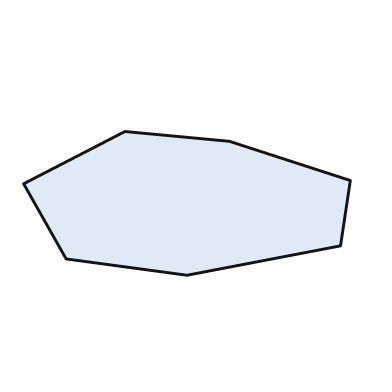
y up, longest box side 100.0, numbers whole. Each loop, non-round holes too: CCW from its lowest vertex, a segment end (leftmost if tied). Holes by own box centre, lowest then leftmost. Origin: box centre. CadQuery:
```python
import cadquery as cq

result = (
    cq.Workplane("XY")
    .moveTo(0.0, -22.0)
    .lineTo(47.0, -13.0)
    .lineTo(50.0, 7.0)
    .lineTo(13.0, 19.0)
    .lineTo(-19.0, 22.0)
    .lineTo(-50.0, 6.0)
    .lineTo(-37.0, -17.0)
    .close()
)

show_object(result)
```